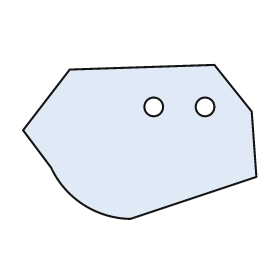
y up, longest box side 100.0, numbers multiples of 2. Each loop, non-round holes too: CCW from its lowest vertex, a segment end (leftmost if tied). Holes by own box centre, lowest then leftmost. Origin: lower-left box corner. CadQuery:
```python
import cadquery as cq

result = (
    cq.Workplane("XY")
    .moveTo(46.0, 0.0)
    .lineTo(100.0, 18.0)
    .lineTo(98.0, 46.0)
    .lineTo(82.0, 66.0)
    .lineTo(20.0, 64.0)
    .lineTo(0.0, 38.0)
    .lineTo(12.0, 22.0)
    .threePointArc((26.0, 6.0), (46.0, 0.0))
    .close()
    .moveTo(56.0, 48.0)
    .circle(4.0)
    .moveTo(78.0, 48.0)
    .circle(4.0)
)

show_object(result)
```